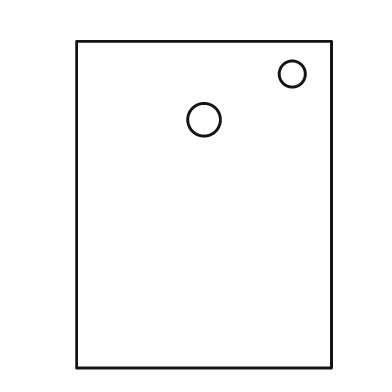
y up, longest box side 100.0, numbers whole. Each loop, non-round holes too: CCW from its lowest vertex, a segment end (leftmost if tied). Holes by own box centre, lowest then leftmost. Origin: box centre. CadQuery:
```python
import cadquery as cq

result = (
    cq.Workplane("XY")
    .moveTo(-39.0, -50.0)
    .lineTo(39.0, -50.0)
    .lineTo(39.0, 50.0)
    .lineTo(-39.0, 50.0)
    .close()
    .moveTo(0.0, 26.0)
    .circle(5.0)
    .moveTo(27.0, 40.0)
    .circle(4.0)
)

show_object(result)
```